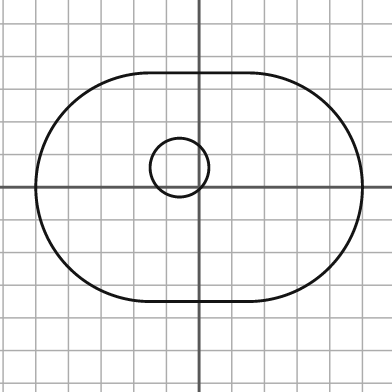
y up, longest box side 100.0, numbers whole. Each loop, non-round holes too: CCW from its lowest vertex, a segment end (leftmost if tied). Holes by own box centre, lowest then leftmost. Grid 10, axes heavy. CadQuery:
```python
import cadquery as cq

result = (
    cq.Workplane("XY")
    .moveTo(-15.0, -35.0)
    .lineTo(15.0, -35.0)
    .threePointArc((50.0, 0.0), (15.0, 35.0))
    .lineTo(-15.0, 35.0)
    .threePointArc((-50.0, 0.0), (-15.0, -35.0))
    .close()
    .moveTo(-6.0, 6.0)
    .circle(9.0)
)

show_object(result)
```